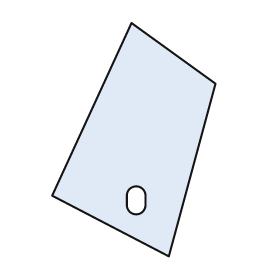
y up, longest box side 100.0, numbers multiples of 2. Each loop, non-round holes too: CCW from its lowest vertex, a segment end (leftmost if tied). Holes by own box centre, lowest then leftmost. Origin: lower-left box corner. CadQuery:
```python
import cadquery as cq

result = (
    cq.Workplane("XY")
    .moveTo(50.0, 0.0)
    .lineTo(70.0, 74.0)
    .lineTo(34.0, 100.0)
    .lineTo(0.0, 26.0)
    .close()
    .moveTo(32.0, 22.0)
    .threePointArc((36.0, 18.0), (40.0, 22.0))
    .lineTo(40.0, 26.0)
    .threePointArc((36.0, 30.0), (32.0, 26.0))
    .close()
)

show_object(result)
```